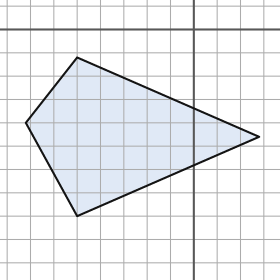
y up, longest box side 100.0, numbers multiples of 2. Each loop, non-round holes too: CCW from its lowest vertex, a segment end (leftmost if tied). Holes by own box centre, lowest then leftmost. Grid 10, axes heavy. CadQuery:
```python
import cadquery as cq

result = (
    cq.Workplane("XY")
    .moveTo(-50.0, -80.0)
    .lineTo(28.0, -46.0)
    .lineTo(-50.0, -12.0)
    .lineTo(-72.0, -40.0)
    .close()
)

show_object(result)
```